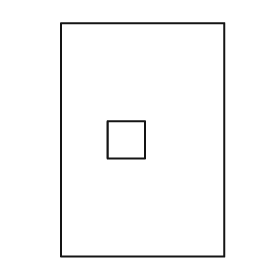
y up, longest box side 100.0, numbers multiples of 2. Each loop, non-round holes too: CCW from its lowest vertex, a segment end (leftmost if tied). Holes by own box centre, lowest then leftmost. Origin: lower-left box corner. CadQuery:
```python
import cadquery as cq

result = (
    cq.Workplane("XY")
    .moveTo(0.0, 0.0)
    .lineTo(70.0, 0.0)
    .lineTo(70.0, 100.0)
    .lineTo(0.0, 100.0)
    .close()
    .moveTo(20.0, 42.0)
    .lineTo(36.0, 42.0)
    .lineTo(36.0, 58.0)
    .lineTo(20.0, 58.0)
    .close()
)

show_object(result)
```